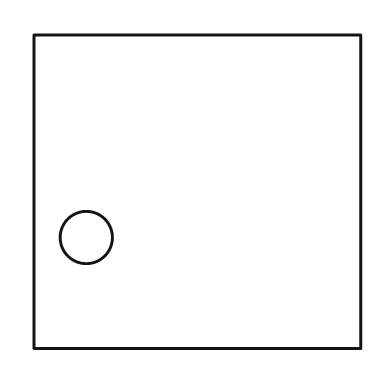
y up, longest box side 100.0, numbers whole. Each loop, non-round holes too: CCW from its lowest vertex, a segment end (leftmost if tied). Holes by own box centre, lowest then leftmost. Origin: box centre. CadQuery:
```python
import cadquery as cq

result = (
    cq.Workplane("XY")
    .moveTo(-50.0, -48.0)
    .lineTo(50.0, -48.0)
    .lineTo(50.0, 48.0)
    .lineTo(-50.0, 48.0)
    .close()
    .moveTo(-34.0, -14.0)
    .circle(8.0)
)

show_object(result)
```